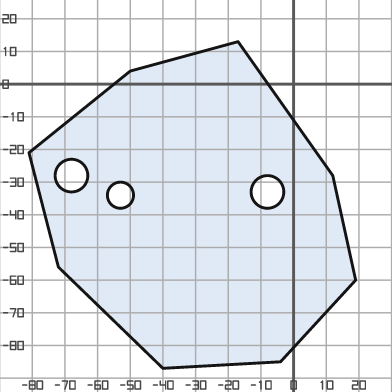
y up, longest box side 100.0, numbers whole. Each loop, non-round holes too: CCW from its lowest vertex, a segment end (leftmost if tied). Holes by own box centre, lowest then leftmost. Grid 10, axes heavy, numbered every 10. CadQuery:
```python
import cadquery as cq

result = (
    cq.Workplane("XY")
    .moveTo(-40.0, -87.0)
    .lineTo(-4.0, -85.0)
    .lineTo(19.0, -60.0)
    .lineTo(12.0, -28.0)
    .lineTo(-17.0, 13.0)
    .lineTo(-50.0, 4.0)
    .lineTo(-81.0, -21.0)
    .lineTo(-72.0, -56.0)
    .close()
    .moveTo(-53.0, -34.0)
    .circle(4.0)
    .moveTo(-8.0, -33.0)
    .circle(5.0)
    .moveTo(-68.0, -28.0)
    .circle(5.0)
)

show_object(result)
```